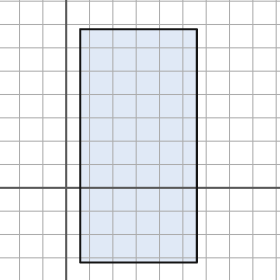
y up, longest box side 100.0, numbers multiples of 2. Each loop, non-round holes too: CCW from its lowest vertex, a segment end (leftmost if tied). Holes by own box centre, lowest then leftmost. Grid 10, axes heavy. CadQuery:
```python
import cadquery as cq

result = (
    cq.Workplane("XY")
    .moveTo(6.0, -32.0)
    .lineTo(56.0, -32.0)
    .lineTo(56.0, 68.0)
    .lineTo(6.0, 68.0)
    .close()
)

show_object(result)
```